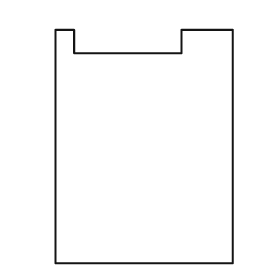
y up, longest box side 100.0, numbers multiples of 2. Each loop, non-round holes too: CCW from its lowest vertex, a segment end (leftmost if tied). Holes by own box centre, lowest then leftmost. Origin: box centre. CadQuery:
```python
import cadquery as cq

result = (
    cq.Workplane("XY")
    .moveTo(-38.0, -50.0)
    .lineTo(38.0, -50.0)
    .lineTo(38.0, 50.0)
    .lineTo(16.0, 50.0)
    .lineTo(16.0, 40.0)
    .lineTo(-30.0, 40.0)
    .lineTo(-30.0, 50.0)
    .lineTo(-38.0, 50.0)
    .close()
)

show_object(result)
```